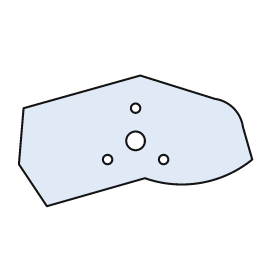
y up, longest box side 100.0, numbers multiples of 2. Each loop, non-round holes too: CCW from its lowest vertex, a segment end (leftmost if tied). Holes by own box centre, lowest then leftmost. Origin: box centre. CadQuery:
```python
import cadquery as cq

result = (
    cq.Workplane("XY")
    .moveTo(-38.0, -28.0)
    .lineTo(4.0, -16.0)
    .threePointArc((28.0, -18.0), (50.0, -8.0))
    .lineTo(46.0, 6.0)
    .threePointArc((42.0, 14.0), (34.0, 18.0))
    .lineTo(2.0, 28.0)
    .lineTo(-48.0, 14.0)
    .lineTo(-50.0, -10.0)
    .close()
    .moveTo(-12.0, -8.0)
    .circle(2.0)
    .moveTo(12.0, -8.0)
    .circle(2.0)
    .moveTo(0.0, 0.0)
    .circle(4.0)
    .moveTo(0.0, 14.0)
    .circle(2.0)
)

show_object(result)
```